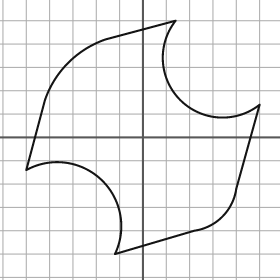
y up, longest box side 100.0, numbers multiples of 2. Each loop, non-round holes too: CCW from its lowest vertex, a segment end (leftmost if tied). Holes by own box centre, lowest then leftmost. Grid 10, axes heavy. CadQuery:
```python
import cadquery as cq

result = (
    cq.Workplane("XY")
    .moveTo(-12.0, -50.0)
    .lineTo(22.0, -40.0)
    .threePointArc((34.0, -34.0), (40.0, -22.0))
    .lineTo(50.0, 14.0)
    .threePointArc((16.0, 16.0), (14.0, 50.0))
    .lineTo(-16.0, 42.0)
    .threePointArc((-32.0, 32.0), (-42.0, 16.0))
    .lineTo(-50.0, -14.0)
    .threePointArc((-18.0, -18.0), (-12.0, -50.0))
    .close()
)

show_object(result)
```